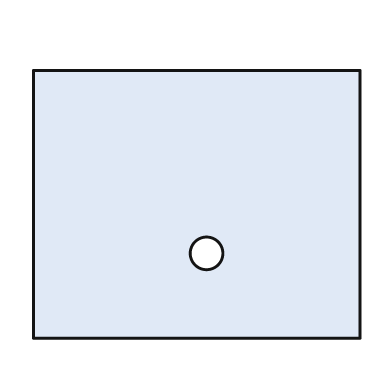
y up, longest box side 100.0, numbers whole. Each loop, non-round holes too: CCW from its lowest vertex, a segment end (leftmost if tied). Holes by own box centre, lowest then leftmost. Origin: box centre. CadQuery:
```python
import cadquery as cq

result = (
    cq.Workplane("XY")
    .moveTo(-50.0, -41.0)
    .lineTo(50.0, -41.0)
    .lineTo(50.0, 41.0)
    .lineTo(-50.0, 41.0)
    .close()
    .moveTo(3.0, -15.0)
    .circle(5.0)
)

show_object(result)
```